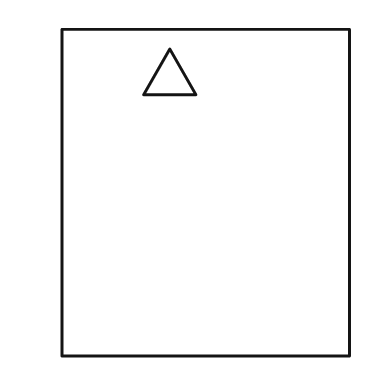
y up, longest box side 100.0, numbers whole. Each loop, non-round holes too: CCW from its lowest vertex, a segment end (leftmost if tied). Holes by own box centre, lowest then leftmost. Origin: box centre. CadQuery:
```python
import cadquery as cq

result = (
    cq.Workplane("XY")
    .moveTo(-44.0, -50.0)
    .lineTo(44.0, -50.0)
    .lineTo(44.0, 50.0)
    .lineTo(-44.0, 50.0)
    .close()
    .moveTo(-19.0, 30.0)
    .lineTo(-3.0, 30.0)
    .lineTo(-11.0, 44.0)
    .close()
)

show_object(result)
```